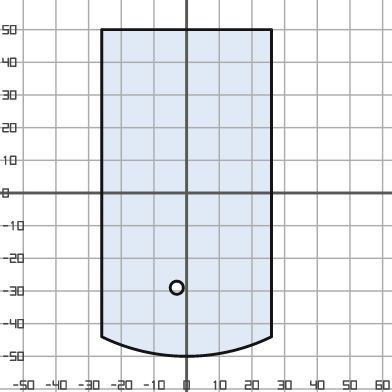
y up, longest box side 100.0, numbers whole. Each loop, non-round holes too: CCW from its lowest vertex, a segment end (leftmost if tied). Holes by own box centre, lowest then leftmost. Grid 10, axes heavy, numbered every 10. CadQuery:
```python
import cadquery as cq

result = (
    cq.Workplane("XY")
    .moveTo(-26.0, -44.0)
    .threePointArc((0.0, -50.0), (26.0, -44.0))
    .lineTo(26.0, 50.0)
    .lineTo(-26.0, 50.0)
    .close()
    .moveTo(-3.0, -29.0)
    .circle(2.0)
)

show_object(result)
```